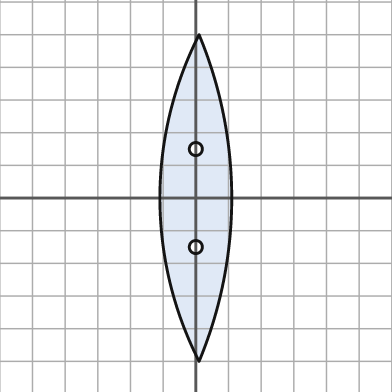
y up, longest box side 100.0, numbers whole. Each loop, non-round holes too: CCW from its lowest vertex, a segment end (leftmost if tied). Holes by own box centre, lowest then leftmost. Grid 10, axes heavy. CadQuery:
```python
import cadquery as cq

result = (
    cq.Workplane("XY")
    .moveTo(1.0, -50.0)
    .threePointArc((11.0, 0.0), (1.0, 50.0))
    .threePointArc((-11.0, 0.0), (1.0, -50.0))
    .close()
    .moveTo(0.0, -15.0)
    .circle(2.0)
    .moveTo(0.0, 15.0)
    .circle(2.0)
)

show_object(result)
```